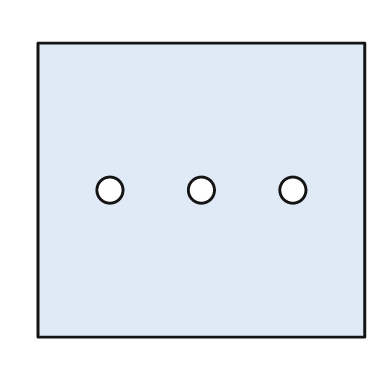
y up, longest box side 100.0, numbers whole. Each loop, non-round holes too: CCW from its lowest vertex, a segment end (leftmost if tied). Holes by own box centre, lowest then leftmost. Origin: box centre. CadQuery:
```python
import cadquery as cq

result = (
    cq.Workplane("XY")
    .moveTo(-50.0, -45.0)
    .lineTo(50.0, -45.0)
    .lineTo(50.0, 45.0)
    .lineTo(-50.0, 45.0)
    .close()
    .moveTo(-28.0, 0.0)
    .circle(4.0)
    .moveTo(0.0, 0.0)
    .circle(4.0)
    .moveTo(28.0, 0.0)
    .circle(4.0)
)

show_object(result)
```